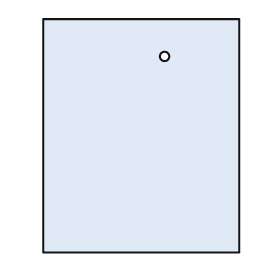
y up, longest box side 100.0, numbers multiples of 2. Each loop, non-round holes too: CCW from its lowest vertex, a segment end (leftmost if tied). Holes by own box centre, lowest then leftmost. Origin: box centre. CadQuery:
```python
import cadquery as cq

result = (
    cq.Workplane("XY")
    .moveTo(-42.0, -50.0)
    .lineTo(42.0, -50.0)
    .lineTo(42.0, 50.0)
    .lineTo(-42.0, 50.0)
    .close()
    .moveTo(10.0, 34.0)
    .circle(2.0)
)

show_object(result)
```